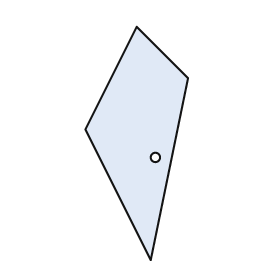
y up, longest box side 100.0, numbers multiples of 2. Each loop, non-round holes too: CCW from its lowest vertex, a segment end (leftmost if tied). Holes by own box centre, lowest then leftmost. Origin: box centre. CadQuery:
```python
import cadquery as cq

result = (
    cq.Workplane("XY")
    .moveTo(6.0, -50.0)
    .lineTo(22.0, 28.0)
    .lineTo(0.0, 50.0)
    .lineTo(-22.0, 6.0)
    .close()
    .moveTo(8.0, -6.0)
    .circle(2.0)
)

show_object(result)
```